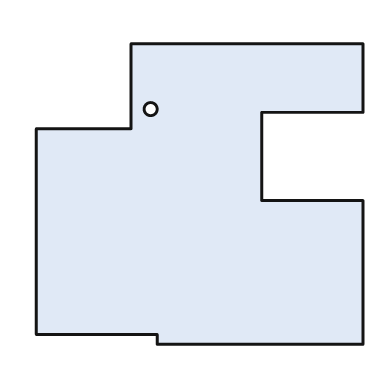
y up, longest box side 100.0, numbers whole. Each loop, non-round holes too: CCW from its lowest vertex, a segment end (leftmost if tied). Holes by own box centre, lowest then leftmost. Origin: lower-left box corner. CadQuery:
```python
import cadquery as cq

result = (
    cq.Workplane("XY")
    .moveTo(37.0, 0.0)
    .lineTo(100.0, 0.0)
    .lineTo(100.0, 44.0)
    .lineTo(69.0, 44.0)
    .lineTo(69.0, 71.0)
    .lineTo(100.0, 71.0)
    .lineTo(100.0, 92.0)
    .lineTo(29.0, 92.0)
    .lineTo(29.0, 66.0)
    .lineTo(0.0, 66.0)
    .lineTo(0.0, 3.0)
    .lineTo(37.0, 3.0)
    .close()
    .moveTo(35.0, 72.0)
    .circle(2.0)
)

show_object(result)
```